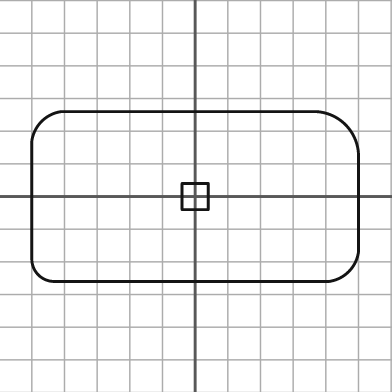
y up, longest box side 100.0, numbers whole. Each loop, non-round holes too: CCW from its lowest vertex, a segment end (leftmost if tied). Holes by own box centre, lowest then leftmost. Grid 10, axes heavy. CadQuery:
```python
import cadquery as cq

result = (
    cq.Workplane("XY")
    .moveTo(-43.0, -26.0)
    .lineTo(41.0, -26.0)
    .threePointArc((47.0, -23.0), (50.0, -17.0))
    .lineTo(50.0, 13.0)
    .threePointArc((46.0, 22.0), (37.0, 26.0))
    .lineTo(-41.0, 26.0)
    .threePointArc((-47.0, 23.0), (-50.0, 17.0))
    .lineTo(-50.0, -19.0)
    .threePointArc((-48.0, -24.0), (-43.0, -26.0))
    .close()
    .moveTo(-4.0, -4.0)
    .lineTo(4.0, -4.0)
    .lineTo(4.0, 4.0)
    .lineTo(-4.0, 4.0)
    .close()
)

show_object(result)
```